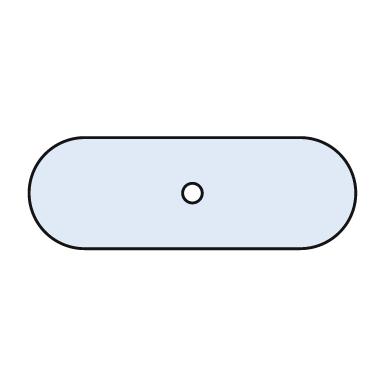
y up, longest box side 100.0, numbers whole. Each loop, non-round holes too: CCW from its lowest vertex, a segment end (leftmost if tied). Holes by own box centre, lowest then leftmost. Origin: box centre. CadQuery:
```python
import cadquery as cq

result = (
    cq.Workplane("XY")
    .moveTo(-33.0, -17.0)
    .lineTo(33.0, -17.0)
    .threePointArc((50.0, 0.0), (33.0, 17.0))
    .lineTo(-33.0, 17.0)
    .threePointArc((-50.0, 0.0), (-33.0, -17.0))
    .close()
    .moveTo(0.0, 0.0)
    .circle(3.0)
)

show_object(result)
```